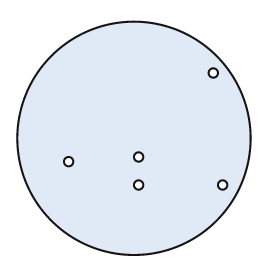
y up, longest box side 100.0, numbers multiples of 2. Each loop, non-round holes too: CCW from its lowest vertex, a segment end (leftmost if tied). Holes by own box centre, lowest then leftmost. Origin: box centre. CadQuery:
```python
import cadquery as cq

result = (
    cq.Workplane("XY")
    .moveTo(0.0, 0.0)
    .circle(50.0)
    .moveTo(2.0, -20.0)
    .circle(2.0)
    .moveTo(38.0, -20.0)
    .circle(2.0)
    .moveTo(-28.0, -10.0)
    .circle(2.0)
    .moveTo(2.0, -8.0)
    .circle(2.0)
    .moveTo(34.0, 28.0)
    .circle(2.0)
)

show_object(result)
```